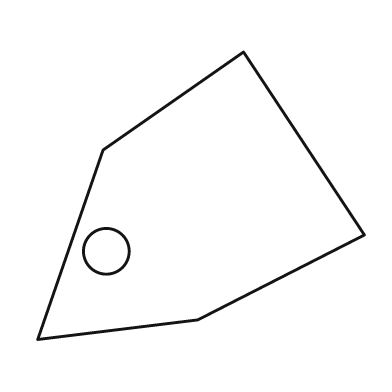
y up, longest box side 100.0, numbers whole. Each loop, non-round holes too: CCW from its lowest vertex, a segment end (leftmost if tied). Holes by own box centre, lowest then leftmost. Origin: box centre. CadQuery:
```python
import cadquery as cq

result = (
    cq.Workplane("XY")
    .moveTo(-50.0, -44.0)
    .lineTo(-1.0, -38.0)
    .lineTo(50.0, -12.0)
    .lineTo(13.0, 44.0)
    .lineTo(-30.0, 14.0)
    .close()
    .moveTo(-29.0, -17.0)
    .circle(7.0)
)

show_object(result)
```